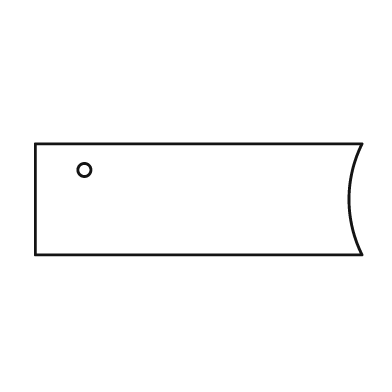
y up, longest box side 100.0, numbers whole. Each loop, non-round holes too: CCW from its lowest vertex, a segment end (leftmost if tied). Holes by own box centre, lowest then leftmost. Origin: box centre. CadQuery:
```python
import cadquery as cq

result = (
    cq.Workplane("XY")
    .moveTo(-50.0, -17.0)
    .lineTo(50.0, -17.0)
    .threePointArc((46.0, 0.0), (50.0, 17.0))
    .lineTo(-50.0, 17.0)
    .close()
    .moveTo(-35.0, 9.0)
    .circle(2.0)
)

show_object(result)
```